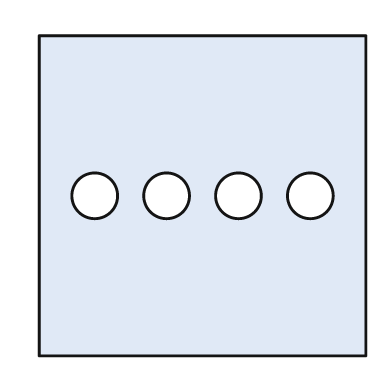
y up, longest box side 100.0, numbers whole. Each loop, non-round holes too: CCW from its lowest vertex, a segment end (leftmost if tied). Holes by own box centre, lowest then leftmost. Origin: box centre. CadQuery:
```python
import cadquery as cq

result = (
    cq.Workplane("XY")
    .moveTo(-50.0, -49.0)
    .lineTo(50.0, -49.0)
    .lineTo(50.0, 49.0)
    .lineTo(-50.0, 49.0)
    .close()
    .moveTo(-33.0, 0.0)
    .circle(7.0)
    .moveTo(-11.0, 0.0)
    .circle(7.0)
    .moveTo(11.0, 0.0)
    .circle(7.0)
    .moveTo(33.0, 0.0)
    .circle(7.0)
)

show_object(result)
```